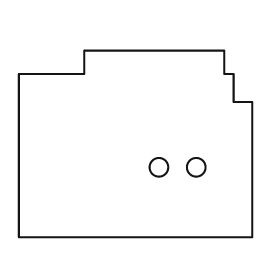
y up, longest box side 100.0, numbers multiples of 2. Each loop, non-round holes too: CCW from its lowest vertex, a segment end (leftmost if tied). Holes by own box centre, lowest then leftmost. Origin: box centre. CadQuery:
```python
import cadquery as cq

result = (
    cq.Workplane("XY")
    .moveTo(-50.0, -40.0)
    .lineTo(50.0, -40.0)
    .lineTo(50.0, 18.0)
    .lineTo(42.0, 18.0)
    .lineTo(42.0, 30.0)
    .lineTo(38.0, 30.0)
    .lineTo(38.0, 40.0)
    .lineTo(-22.0, 40.0)
    .lineTo(-22.0, 30.0)
    .lineTo(-50.0, 30.0)
    .close()
    .moveTo(10.0, -10.0)
    .circle(4.0)
    .moveTo(26.0, -10.0)
    .circle(4.0)
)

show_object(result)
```